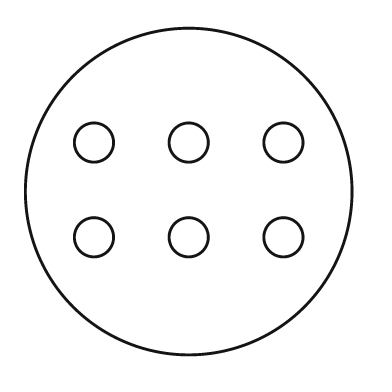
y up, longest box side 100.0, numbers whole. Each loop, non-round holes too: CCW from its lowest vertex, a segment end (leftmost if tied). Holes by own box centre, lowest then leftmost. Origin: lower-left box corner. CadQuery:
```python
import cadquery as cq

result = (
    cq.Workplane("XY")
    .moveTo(50.0, 50.0)
    .circle(50.0)
    .moveTo(21.0, 36.0)
    .circle(6.0)
    .moveTo(50.0, 36.0)
    .circle(6.0)
    .moveTo(79.0, 36.0)
    .circle(6.0)
    .moveTo(21.0, 65.0)
    .circle(6.0)
    .moveTo(50.0, 65.0)
    .circle(6.0)
    .moveTo(79.0, 65.0)
    .circle(6.0)
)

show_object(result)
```